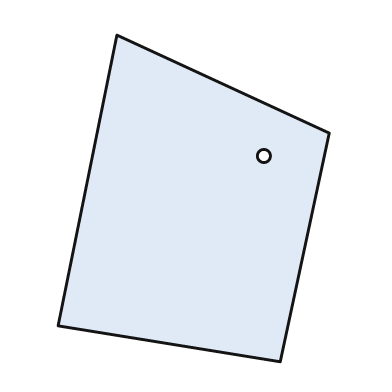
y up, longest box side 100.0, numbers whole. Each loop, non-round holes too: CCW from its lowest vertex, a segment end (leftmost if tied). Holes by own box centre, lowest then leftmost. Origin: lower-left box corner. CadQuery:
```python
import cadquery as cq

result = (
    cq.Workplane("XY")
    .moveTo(68.0, 0.0)
    .lineTo(83.0, 70.0)
    .lineTo(18.0, 100.0)
    .lineTo(0.0, 11.0)
    .close()
    .moveTo(63.0, 63.0)
    .circle(2.0)
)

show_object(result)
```